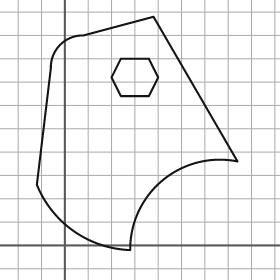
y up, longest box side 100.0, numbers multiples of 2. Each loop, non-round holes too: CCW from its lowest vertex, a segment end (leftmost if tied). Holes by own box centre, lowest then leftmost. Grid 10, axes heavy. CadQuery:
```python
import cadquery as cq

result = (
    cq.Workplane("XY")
    .moveTo(28.0, -2.0)
    .threePointArc((42.0, 28.0), (74.0, 36.0))
    .lineTo(38.0, 98.0)
    .lineTo(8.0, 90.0)
    .threePointArc((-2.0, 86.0), (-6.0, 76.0))
    .lineTo(-12.0, 26.0)
    .threePointArc((4.0, 6.0), (28.0, -2.0))
    .close()
    .moveTo(24.0, 64.0)
    .lineTo(36.0, 64.0)
    .lineTo(40.0, 72.0)
    .lineTo(36.0, 80.0)
    .lineTo(24.0, 80.0)
    .lineTo(20.0, 72.0)
    .close()
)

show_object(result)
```